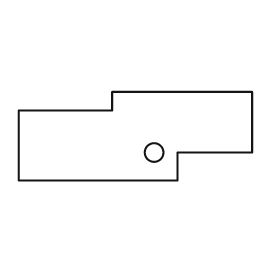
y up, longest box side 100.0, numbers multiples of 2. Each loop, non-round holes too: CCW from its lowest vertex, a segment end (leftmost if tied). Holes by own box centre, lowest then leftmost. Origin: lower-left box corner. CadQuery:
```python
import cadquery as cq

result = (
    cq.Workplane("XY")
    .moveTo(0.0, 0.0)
    .lineTo(68.0, 0.0)
    .lineTo(68.0, 12.0)
    .lineTo(100.0, 12.0)
    .lineTo(100.0, 38.0)
    .lineTo(40.0, 38.0)
    .lineTo(40.0, 30.0)
    .lineTo(0.0, 30.0)
    .close()
    .moveTo(58.0, 12.0)
    .circle(4.0)
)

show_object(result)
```